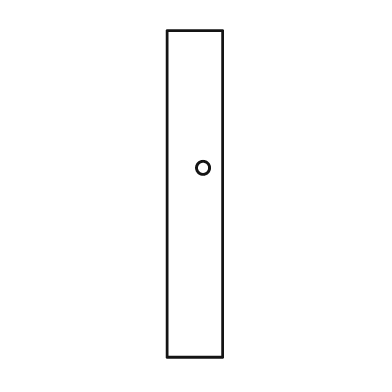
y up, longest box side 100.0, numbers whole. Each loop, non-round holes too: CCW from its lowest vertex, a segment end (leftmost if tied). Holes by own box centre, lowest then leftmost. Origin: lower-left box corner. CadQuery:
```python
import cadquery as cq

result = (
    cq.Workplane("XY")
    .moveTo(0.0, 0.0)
    .lineTo(17.0, 0.0)
    .lineTo(17.0, 100.0)
    .lineTo(0.0, 100.0)
    .close()
    .moveTo(11.0, 58.0)
    .circle(2.0)
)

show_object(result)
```